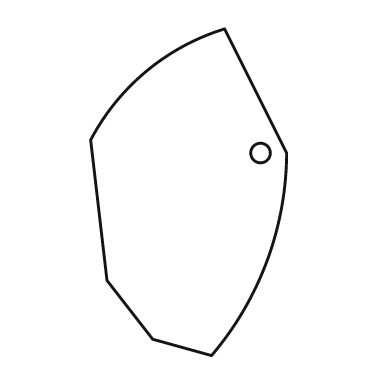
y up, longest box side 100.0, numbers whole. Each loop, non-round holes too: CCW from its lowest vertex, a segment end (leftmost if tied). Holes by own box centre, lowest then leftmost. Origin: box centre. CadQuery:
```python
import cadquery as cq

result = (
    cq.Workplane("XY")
    .moveTo(7.0, -50.0)
    .threePointArc((24.0, -21.0), (30.0, 12.0))
    .lineTo(11.0, 50.0)
    .threePointArc((-13.0, 37.0), (-30.0, 16.0))
    .lineTo(-25.0, -27.0)
    .lineTo(-11.0, -45.0)
    .close()
    .moveTo(22.0, 12.0)
    .circle(3.0)
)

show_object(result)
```